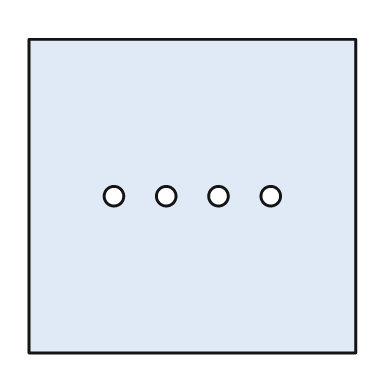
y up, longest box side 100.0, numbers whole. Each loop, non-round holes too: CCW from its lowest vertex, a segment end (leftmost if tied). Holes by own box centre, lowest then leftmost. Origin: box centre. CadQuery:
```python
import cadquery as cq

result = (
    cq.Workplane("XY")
    .moveTo(-50.0, -48.0)
    .lineTo(50.0, -48.0)
    .lineTo(50.0, 48.0)
    .lineTo(-50.0, 48.0)
    .close()
    .moveTo(-24.0, 0.0)
    .circle(3.0)
    .moveTo(-8.0, 0.0)
    .circle(3.0)
    .moveTo(8.0, 0.0)
    .circle(3.0)
    .moveTo(24.0, 0.0)
    .circle(3.0)
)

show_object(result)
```